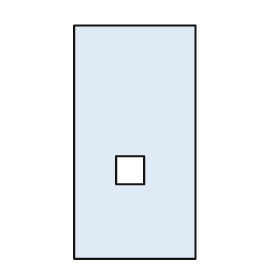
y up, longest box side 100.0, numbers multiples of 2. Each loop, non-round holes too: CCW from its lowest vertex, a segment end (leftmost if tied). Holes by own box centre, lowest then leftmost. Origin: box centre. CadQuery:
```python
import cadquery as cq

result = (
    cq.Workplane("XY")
    .moveTo(-26.0, -50.0)
    .lineTo(26.0, -50.0)
    .lineTo(26.0, 50.0)
    .lineTo(-26.0, 50.0)
    .close()
    .moveTo(-8.0, -18.0)
    .lineTo(4.0, -18.0)
    .lineTo(4.0, -6.0)
    .lineTo(-8.0, -6.0)
    .close()
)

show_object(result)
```